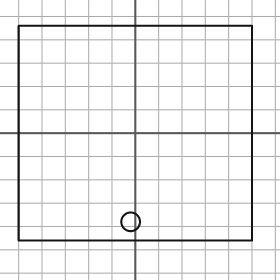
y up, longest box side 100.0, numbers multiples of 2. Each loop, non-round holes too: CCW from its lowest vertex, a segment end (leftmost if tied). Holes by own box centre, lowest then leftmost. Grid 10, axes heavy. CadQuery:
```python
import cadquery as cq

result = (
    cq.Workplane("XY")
    .moveTo(-50.0, -46.0)
    .lineTo(50.0, -46.0)
    .lineTo(50.0, 46.0)
    .lineTo(-50.0, 46.0)
    .close()
    .moveTo(-2.0, -38.0)
    .circle(4.0)
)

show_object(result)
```